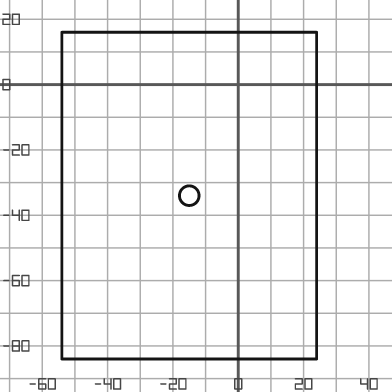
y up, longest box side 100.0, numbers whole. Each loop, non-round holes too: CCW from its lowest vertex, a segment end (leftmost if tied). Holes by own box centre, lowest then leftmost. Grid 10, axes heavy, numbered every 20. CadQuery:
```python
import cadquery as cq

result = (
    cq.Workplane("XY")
    .moveTo(-54.0, -84.0)
    .lineTo(24.0, -84.0)
    .lineTo(24.0, 16.0)
    .lineTo(-54.0, 16.0)
    .close()
    .moveTo(-15.0, -34.0)
    .circle(3.0)
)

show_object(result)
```